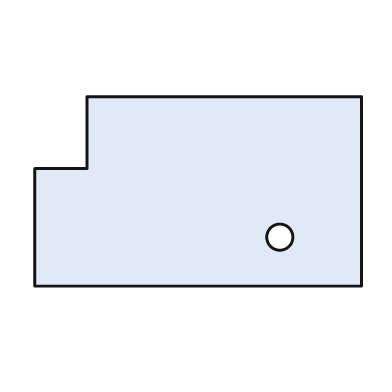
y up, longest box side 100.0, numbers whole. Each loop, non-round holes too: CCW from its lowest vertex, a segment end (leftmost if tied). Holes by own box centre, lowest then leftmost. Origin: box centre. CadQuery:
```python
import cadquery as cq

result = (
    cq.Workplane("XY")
    .moveTo(-50.0, -29.0)
    .lineTo(50.0, -29.0)
    .lineTo(50.0, 29.0)
    .lineTo(-34.0, 29.0)
    .lineTo(-34.0, 7.0)
    .lineTo(-50.0, 7.0)
    .close()
    .moveTo(25.0, -14.0)
    .circle(4.0)
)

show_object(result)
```